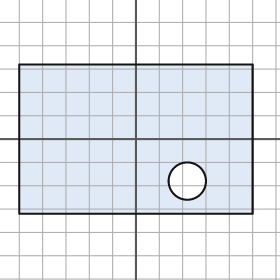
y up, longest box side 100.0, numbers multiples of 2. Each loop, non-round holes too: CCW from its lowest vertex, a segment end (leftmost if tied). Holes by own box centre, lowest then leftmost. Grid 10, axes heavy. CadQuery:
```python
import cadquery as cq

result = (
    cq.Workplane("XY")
    .moveTo(-50.0, -32.0)
    .lineTo(50.0, -32.0)
    .lineTo(50.0, 32.0)
    .lineTo(-50.0, 32.0)
    .close()
    .moveTo(22.0, -18.0)
    .circle(8.0)
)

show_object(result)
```